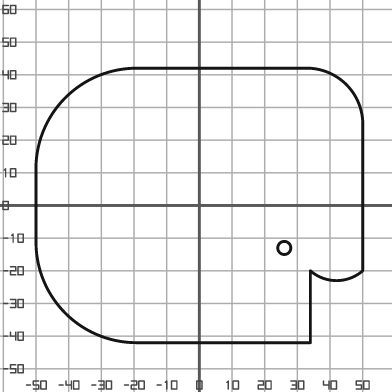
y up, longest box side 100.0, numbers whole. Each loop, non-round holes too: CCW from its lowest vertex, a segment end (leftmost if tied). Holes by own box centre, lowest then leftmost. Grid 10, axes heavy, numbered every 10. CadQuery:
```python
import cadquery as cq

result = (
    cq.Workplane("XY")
    .moveTo(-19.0, -42.0)
    .lineTo(34.0, -42.0)
    .lineTo(34.0, -20.0)
    .threePointArc((42.0, -23.0), (50.0, -20.0))
    .lineTo(50.0, 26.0)
    .threePointArc((45.0, 37.0), (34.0, 42.0))
    .lineTo(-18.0, 42.0)
    .threePointArc((-41.0, 33.0), (-50.0, 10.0))
    .lineTo(-50.0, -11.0)
    .threePointArc((-41.0, -33.0), (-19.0, -42.0))
    .close()
    .moveTo(26.0, -13.0)
    .circle(2.0)
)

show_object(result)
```